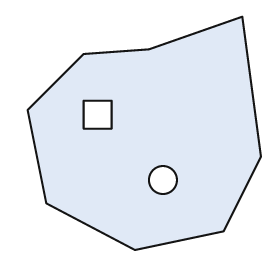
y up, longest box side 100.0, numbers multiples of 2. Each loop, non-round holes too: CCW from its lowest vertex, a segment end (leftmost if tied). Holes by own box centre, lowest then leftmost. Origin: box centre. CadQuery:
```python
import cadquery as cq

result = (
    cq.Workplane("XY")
    .moveTo(-4.0, -50.0)
    .lineTo(34.0, -42.0)
    .lineTo(50.0, -10.0)
    .lineTo(42.0, 50.0)
    .lineTo(2.0, 36.0)
    .lineTo(-26.0, 34.0)
    .lineTo(-50.0, 10.0)
    .lineTo(-42.0, -30.0)
    .close()
    .moveTo(8.0, -20.0)
    .circle(6.0)
    .moveTo(-26.0, 2.0)
    .lineTo(-14.0, 2.0)
    .lineTo(-14.0, 14.0)
    .lineTo(-26.0, 14.0)
    .close()
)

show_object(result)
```